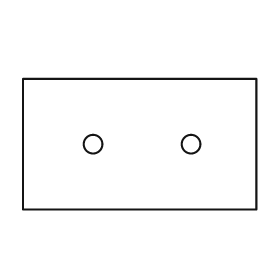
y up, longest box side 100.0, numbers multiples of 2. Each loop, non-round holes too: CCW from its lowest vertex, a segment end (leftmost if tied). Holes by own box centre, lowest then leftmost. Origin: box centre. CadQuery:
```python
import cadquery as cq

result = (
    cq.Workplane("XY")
    .moveTo(-50.0, -28.0)
    .lineTo(50.0, -28.0)
    .lineTo(50.0, 28.0)
    .lineTo(-50.0, 28.0)
    .close()
    .moveTo(-20.0, 0.0)
    .circle(4.0)
    .moveTo(22.0, 0.0)
    .circle(4.0)
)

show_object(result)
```